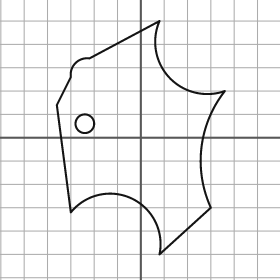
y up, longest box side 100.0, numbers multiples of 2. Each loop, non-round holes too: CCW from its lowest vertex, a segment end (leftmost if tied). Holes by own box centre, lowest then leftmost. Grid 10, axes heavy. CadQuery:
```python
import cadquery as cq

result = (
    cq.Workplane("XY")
    .moveTo(8.0, -50.0)
    .lineTo(30.0, -30.0)
    .threePointArc((26.0, -4.0), (36.0, 20.0))
    .threePointArc((12.0, 26.0), (8.0, 50.0))
    .lineTo(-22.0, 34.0)
    .threePointArc((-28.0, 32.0), (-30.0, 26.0))
    .lineTo(-36.0, 14.0)
    .lineTo(-30.0, -32.0)
    .threePointArc((-4.0, -26.0), (8.0, -50.0))
    .close()
    .moveTo(-24.0, 6.0)
    .circle(4.0)
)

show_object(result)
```